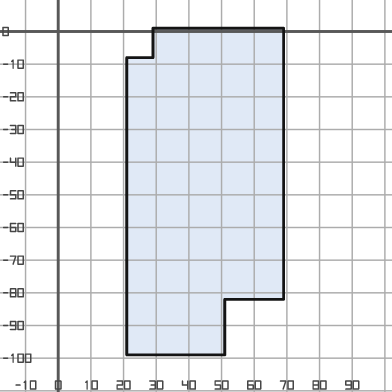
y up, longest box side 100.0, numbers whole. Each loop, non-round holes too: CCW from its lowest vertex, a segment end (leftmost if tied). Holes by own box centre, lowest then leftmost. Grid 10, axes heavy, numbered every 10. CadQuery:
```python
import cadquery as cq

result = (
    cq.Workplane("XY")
    .moveTo(21.0, -99.0)
    .lineTo(51.0, -99.0)
    .lineTo(51.0, -82.0)
    .lineTo(69.0, -82.0)
    .lineTo(69.0, 1.0)
    .lineTo(29.0, 1.0)
    .lineTo(29.0, -8.0)
    .lineTo(21.0, -8.0)
    .close()
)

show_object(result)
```